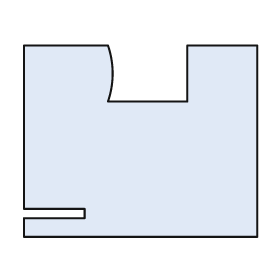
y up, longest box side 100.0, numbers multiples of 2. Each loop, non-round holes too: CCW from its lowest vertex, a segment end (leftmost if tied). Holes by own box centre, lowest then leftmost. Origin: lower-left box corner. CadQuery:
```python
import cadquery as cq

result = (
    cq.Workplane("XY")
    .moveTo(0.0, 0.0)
    .lineTo(100.0, 0.0)
    .lineTo(100.0, 82.0)
    .lineTo(70.0, 82.0)
    .lineTo(70.0, 58.0)
    .lineTo(36.0, 58.0)
    .threePointArc((38.0, 70.0), (36.0, 82.0))
    .lineTo(0.0, 82.0)
    .lineTo(0.0, 12.0)
    .lineTo(26.0, 12.0)
    .lineTo(26.0, 8.0)
    .lineTo(0.0, 8.0)
    .close()
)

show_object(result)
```